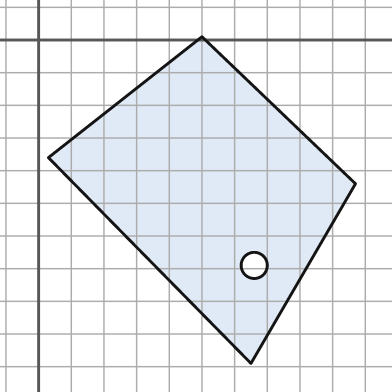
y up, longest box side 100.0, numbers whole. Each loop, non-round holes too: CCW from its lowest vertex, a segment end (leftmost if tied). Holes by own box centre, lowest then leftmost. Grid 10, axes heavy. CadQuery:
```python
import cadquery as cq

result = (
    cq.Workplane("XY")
    .moveTo(65.0, -99.0)
    .lineTo(97.0, -44.0)
    .lineTo(50.0, 1.0)
    .lineTo(3.0, -36.0)
    .close()
    .moveTo(66.0, -69.0)
    .circle(4.0)
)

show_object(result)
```